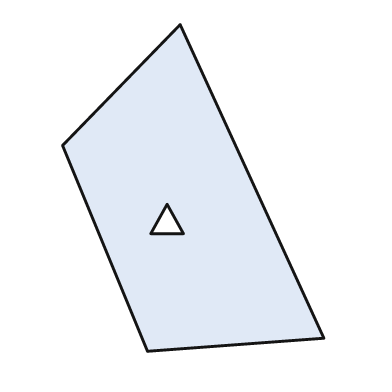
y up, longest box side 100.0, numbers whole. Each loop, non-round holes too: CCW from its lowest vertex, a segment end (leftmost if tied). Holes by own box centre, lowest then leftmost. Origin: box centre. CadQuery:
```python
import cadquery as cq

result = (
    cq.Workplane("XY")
    .moveTo(-14.0, -50.0)
    .lineTo(40.0, -46.0)
    .lineTo(-4.0, 50.0)
    .lineTo(-40.0, 13.0)
    .close()
    .moveTo(-13.0, -14.0)
    .lineTo(-3.0, -14.0)
    .lineTo(-8.0, -5.0)
    .close()
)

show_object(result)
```